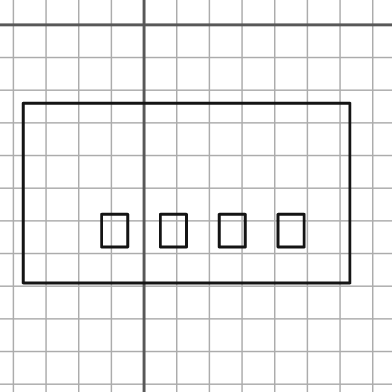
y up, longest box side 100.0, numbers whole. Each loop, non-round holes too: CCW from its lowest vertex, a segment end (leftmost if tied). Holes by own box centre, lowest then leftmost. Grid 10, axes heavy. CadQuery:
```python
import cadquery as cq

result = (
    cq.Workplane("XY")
    .moveTo(-37.0, -79.0)
    .lineTo(63.0, -79.0)
    .lineTo(63.0, -24.0)
    .lineTo(-37.0, -24.0)
    .close()
    .moveTo(-13.0, -68.0)
    .lineTo(-5.0, -68.0)
    .lineTo(-5.0, -58.0)
    .lineTo(-13.0, -58.0)
    .close()
    .moveTo(5.0, -68.0)
    .lineTo(13.0, -68.0)
    .lineTo(13.0, -58.0)
    .lineTo(5.0, -58.0)
    .close()
    .moveTo(23.0, -68.0)
    .lineTo(31.0, -68.0)
    .lineTo(31.0, -58.0)
    .lineTo(23.0, -58.0)
    .close()
    .moveTo(41.0, -68.0)
    .lineTo(49.0, -68.0)
    .lineTo(49.0, -58.0)
    .lineTo(41.0, -58.0)
    .close()
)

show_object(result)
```